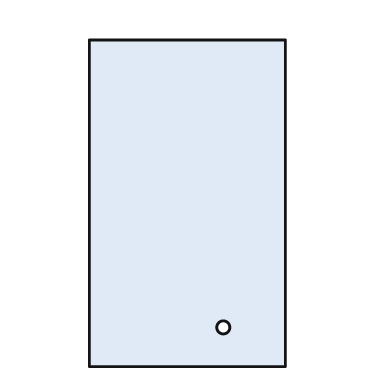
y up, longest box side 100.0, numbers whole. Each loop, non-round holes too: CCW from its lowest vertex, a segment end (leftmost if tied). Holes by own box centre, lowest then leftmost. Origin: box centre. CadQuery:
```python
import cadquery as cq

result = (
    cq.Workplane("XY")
    .moveTo(-30.0, -50.0)
    .lineTo(30.0, -50.0)
    .lineTo(30.0, 50.0)
    .lineTo(-30.0, 50.0)
    .close()
    .moveTo(11.0, -38.0)
    .circle(2.0)
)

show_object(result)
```